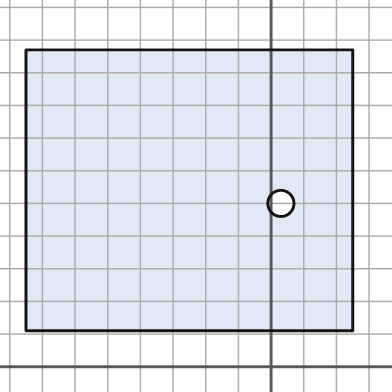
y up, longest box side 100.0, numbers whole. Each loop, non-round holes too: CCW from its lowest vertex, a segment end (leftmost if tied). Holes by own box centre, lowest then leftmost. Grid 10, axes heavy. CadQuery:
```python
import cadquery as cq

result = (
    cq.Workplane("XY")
    .moveTo(-75.0, 11.0)
    .lineTo(25.0, 11.0)
    .lineTo(25.0, 97.0)
    .lineTo(-75.0, 97.0)
    .close()
    .moveTo(3.0, 50.0)
    .circle(4.0)
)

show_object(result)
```